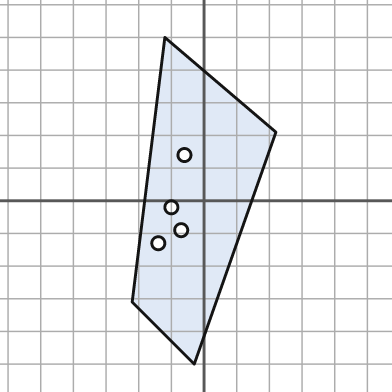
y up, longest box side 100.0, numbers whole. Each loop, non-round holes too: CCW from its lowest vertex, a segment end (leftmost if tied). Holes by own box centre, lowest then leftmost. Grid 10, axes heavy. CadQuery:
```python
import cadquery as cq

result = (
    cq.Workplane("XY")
    .moveTo(-3.0, -50.0)
    .lineTo(22.0, 21.0)
    .lineTo(-12.0, 50.0)
    .lineTo(-22.0, -31.0)
    .close()
    .moveTo(-14.0, -13.0)
    .circle(2.0)
    .moveTo(-7.0, -9.0)
    .circle(2.0)
    .moveTo(-10.0, -2.0)
    .circle(2.0)
    .moveTo(-6.0, 14.0)
    .circle(2.0)
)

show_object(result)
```